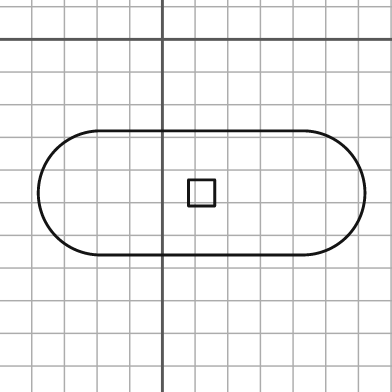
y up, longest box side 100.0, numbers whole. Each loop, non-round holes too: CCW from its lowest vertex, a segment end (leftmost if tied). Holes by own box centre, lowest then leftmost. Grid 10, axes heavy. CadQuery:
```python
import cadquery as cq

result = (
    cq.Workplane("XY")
    .moveTo(-19.0, -66.0)
    .lineTo(43.0, -66.0)
    .threePointArc((62.0, -47.0), (43.0, -28.0))
    .lineTo(-19.0, -28.0)
    .threePointArc((-38.0, -47.0), (-19.0, -66.0))
    .close()
    .moveTo(8.0, -51.0)
    .lineTo(16.0, -51.0)
    .lineTo(16.0, -43.0)
    .lineTo(8.0, -43.0)
    .close()
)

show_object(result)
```